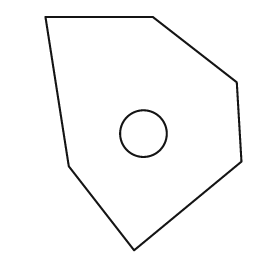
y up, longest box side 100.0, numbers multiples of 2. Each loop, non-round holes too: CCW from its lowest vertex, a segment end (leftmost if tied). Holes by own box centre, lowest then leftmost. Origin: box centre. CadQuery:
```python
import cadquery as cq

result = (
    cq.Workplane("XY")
    .moveTo(-4.0, -50.0)
    .lineTo(42.0, -12.0)
    .lineTo(40.0, 22.0)
    .lineTo(4.0, 50.0)
    .lineTo(-42.0, 50.0)
    .lineTo(-32.0, -14.0)
    .close()
    .moveTo(0.0, 0.0)
    .circle(10.0)
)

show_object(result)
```